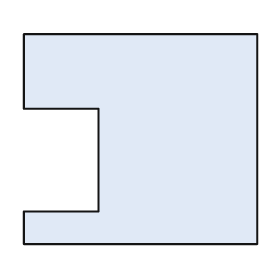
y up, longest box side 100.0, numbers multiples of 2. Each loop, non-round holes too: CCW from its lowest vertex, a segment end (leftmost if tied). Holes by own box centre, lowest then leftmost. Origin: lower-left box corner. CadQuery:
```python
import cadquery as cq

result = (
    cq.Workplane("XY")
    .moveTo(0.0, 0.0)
    .lineTo(100.0, 0.0)
    .lineTo(100.0, 90.0)
    .lineTo(0.0, 90.0)
    .lineTo(0.0, 58.0)
    .lineTo(32.0, 58.0)
    .lineTo(32.0, 14.0)
    .lineTo(0.0, 14.0)
    .close()
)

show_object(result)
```